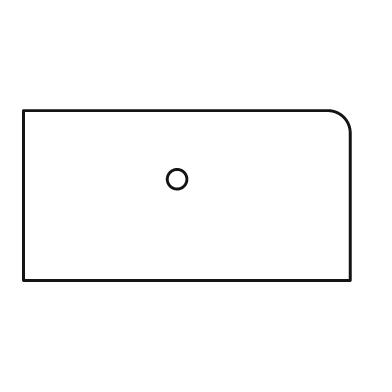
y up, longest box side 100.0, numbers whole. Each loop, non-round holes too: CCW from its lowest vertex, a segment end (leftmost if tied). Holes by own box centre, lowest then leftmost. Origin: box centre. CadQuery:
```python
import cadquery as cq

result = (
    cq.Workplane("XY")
    .moveTo(-50.0, -26.0)
    .lineTo(50.0, -26.0)
    .lineTo(50.0, 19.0)
    .threePointArc((48.0, 24.0), (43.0, 26.0))
    .lineTo(-50.0, 26.0)
    .close()
    .moveTo(-3.0, 5.0)
    .circle(3.0)
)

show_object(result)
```